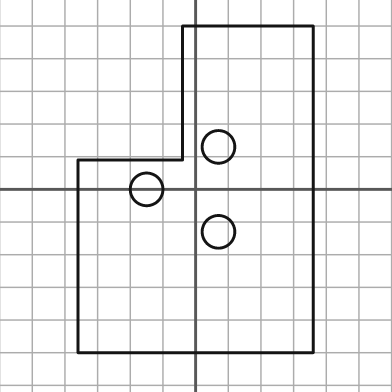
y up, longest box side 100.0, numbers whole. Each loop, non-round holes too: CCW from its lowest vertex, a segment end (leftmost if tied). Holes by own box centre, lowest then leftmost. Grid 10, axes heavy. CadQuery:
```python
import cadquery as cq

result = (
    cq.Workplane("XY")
    .moveTo(-36.0, -50.0)
    .lineTo(36.0, -50.0)
    .lineTo(36.0, 50.0)
    .lineTo(-4.0, 50.0)
    .lineTo(-4.0, 9.0)
    .lineTo(-36.0, 9.0)
    .close()
    .moveTo(7.0, -13.0)
    .circle(5.0)
    .moveTo(-15.0, 0.0)
    .circle(5.0)
    .moveTo(7.0, 13.0)
    .circle(5.0)
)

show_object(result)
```